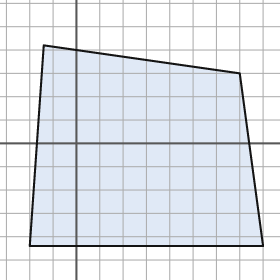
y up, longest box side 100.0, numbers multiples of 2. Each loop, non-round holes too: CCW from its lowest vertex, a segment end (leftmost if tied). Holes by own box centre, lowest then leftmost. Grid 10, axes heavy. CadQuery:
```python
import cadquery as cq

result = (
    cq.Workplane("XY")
    .moveTo(-20.0, -44.0)
    .lineTo(80.0, -44.0)
    .lineTo(70.0, 30.0)
    .lineTo(-14.0, 42.0)
    .close()
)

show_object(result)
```